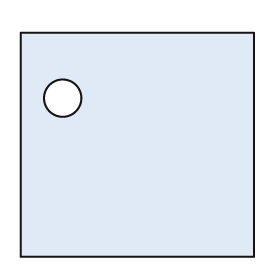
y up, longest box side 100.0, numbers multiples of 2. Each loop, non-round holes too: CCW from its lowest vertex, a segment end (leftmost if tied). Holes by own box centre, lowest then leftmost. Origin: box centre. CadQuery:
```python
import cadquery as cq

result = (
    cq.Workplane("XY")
    .moveTo(-50.0, -48.0)
    .lineTo(50.0, -48.0)
    .lineTo(50.0, 48.0)
    .lineTo(-50.0, 48.0)
    .close()
    .moveTo(-32.0, 20.0)
    .circle(8.0)
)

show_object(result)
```